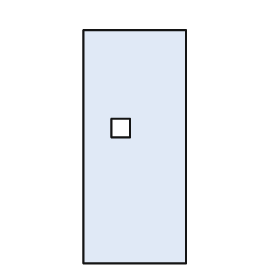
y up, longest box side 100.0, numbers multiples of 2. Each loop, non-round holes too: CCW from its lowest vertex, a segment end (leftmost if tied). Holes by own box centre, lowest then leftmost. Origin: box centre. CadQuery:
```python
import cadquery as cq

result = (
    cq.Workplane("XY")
    .moveTo(-22.0, -50.0)
    .lineTo(22.0, -50.0)
    .lineTo(22.0, 50.0)
    .lineTo(-22.0, 50.0)
    .close()
    .moveTo(-10.0, 4.0)
    .lineTo(-2.0, 4.0)
    .lineTo(-2.0, 12.0)
    .lineTo(-10.0, 12.0)
    .close()
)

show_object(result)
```